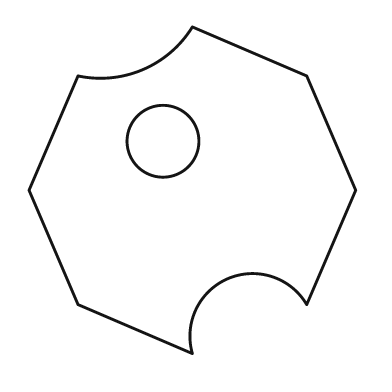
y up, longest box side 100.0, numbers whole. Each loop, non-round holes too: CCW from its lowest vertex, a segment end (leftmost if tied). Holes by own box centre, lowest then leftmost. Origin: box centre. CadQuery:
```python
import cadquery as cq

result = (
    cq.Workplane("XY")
    .moveTo(0.0, -50.0)
    .threePointArc((11.0, -27.0), (35.0, -35.0))
    .lineTo(50.0, 0.0)
    .lineTo(35.0, 35.0)
    .lineTo(0.0, 50.0)
    .threePointArc((-15.0, 37.0), (-35.0, 35.0))
    .lineTo(-50.0, 0.0)
    .lineTo(-35.0, -35.0)
    .close()
    .moveTo(-9.0, 15.0)
    .circle(11.0)
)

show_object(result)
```